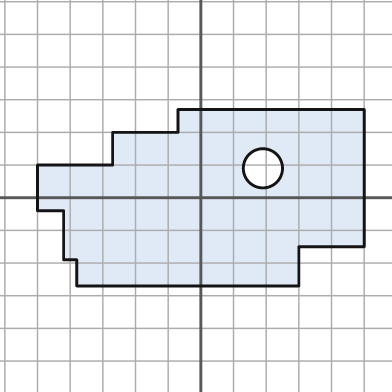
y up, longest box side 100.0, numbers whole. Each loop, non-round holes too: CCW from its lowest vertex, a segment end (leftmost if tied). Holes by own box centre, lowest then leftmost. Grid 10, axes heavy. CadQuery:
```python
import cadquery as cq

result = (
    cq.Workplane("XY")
    .moveTo(-38.0, -27.0)
    .lineTo(30.0, -27.0)
    .lineTo(30.0, -15.0)
    .lineTo(50.0, -15.0)
    .lineTo(50.0, 27.0)
    .lineTo(-7.0, 27.0)
    .lineTo(-7.0, 20.0)
    .lineTo(-27.0, 20.0)
    .lineTo(-27.0, 10.0)
    .lineTo(-50.0, 10.0)
    .lineTo(-50.0, -4.0)
    .lineTo(-42.0, -4.0)
    .lineTo(-42.0, -19.0)
    .lineTo(-38.0, -19.0)
    .close()
    .moveTo(19.0, 9.0)
    .circle(6.0)
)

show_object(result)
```